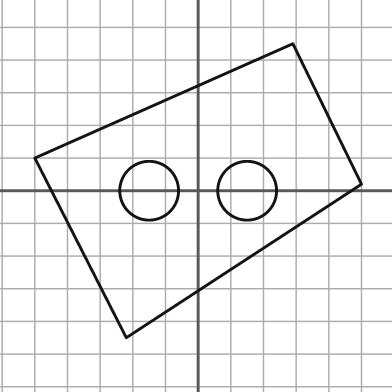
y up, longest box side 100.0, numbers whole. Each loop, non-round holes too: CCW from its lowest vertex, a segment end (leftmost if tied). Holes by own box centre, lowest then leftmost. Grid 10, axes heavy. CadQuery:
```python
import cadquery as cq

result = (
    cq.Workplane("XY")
    .moveTo(-22.0, -45.0)
    .lineTo(50.0, 2.0)
    .lineTo(29.0, 45.0)
    .lineTo(-50.0, 10.0)
    .close()
    .moveTo(-15.0, 0.0)
    .circle(9.0)
    .moveTo(15.0, 0.0)
    .circle(9.0)
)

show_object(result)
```